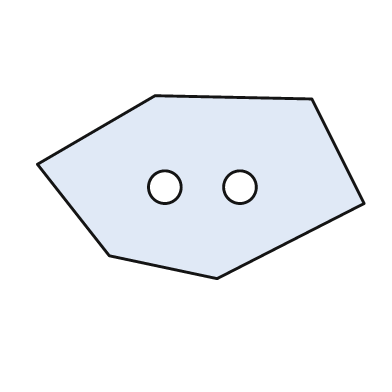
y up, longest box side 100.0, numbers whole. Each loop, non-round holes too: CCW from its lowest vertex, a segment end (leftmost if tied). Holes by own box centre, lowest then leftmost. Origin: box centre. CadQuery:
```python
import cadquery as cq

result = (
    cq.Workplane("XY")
    .moveTo(5.0, -28.0)
    .lineTo(50.0, -5.0)
    .lineTo(34.0, 27.0)
    .lineTo(-14.0, 28.0)
    .lineTo(-50.0, 7.0)
    .lineTo(-28.0, -21.0)
    .close()
    .moveTo(-11.0, 0.0)
    .circle(5.0)
    .moveTo(12.0, 0.0)
    .circle(5.0)
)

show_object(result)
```